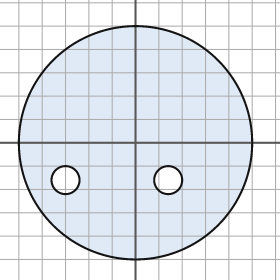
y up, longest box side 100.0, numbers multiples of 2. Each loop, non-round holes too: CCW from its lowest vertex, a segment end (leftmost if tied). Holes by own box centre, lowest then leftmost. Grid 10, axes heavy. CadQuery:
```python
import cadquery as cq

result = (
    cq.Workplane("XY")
    .moveTo(0.0, 0.0)
    .circle(50.0)
    .moveTo(-30.0, -16.0)
    .circle(6.0)
    .moveTo(14.0, -16.0)
    .circle(6.0)
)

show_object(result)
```